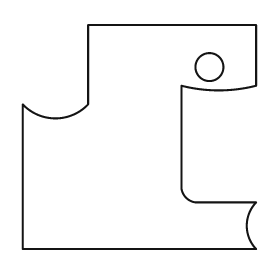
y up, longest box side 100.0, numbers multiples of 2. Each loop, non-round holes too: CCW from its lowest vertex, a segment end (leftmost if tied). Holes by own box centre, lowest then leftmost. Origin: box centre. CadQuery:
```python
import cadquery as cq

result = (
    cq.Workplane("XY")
    .moveTo(-50.0, -48.0)
    .lineTo(50.0, -48.0)
    .threePointArc((46.0, -38.0), (50.0, -28.0))
    .lineTo(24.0, -28.0)
    .threePointArc((20.0, -26.0), (18.0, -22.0))
    .lineTo(18.0, 22.0)
    .threePointArc((34.0, 20.0), (50.0, 22.0))
    .lineTo(50.0, 48.0)
    .lineTo(-22.0, 48.0)
    .lineTo(-22.0, 14.0)
    .threePointArc((-36.0, 8.0), (-50.0, 14.0))
    .close()
    .moveTo(30.0, 30.0)
    .circle(6.0)
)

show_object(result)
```